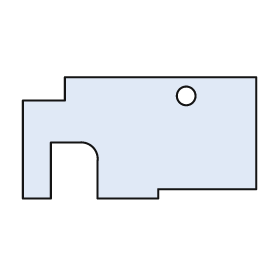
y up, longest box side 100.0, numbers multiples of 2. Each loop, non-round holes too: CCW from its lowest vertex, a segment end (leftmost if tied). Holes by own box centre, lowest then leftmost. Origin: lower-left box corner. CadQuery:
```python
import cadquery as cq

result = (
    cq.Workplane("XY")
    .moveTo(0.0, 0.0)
    .lineTo(12.0, 0.0)
    .lineTo(12.0, 24.0)
    .lineTo(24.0, 24.0)
    .threePointArc((30.0, 22.0), (32.0, 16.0))
    .lineTo(32.0, 0.0)
    .lineTo(58.0, 0.0)
    .lineTo(58.0, 4.0)
    .lineTo(100.0, 4.0)
    .lineTo(100.0, 52.0)
    .lineTo(18.0, 52.0)
    .lineTo(18.0, 42.0)
    .lineTo(0.0, 42.0)
    .close()
    .moveTo(70.0, 44.0)
    .circle(4.0)
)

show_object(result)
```